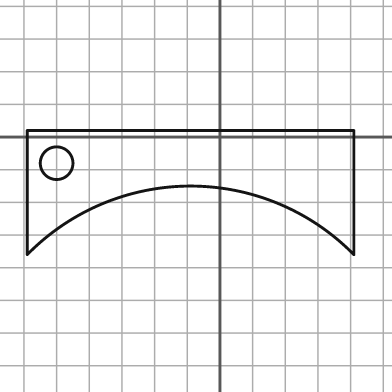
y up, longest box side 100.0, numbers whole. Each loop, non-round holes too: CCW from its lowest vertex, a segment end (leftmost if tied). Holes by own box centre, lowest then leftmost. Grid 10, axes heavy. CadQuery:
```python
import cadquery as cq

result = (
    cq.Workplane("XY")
    .moveTo(-59.0, -36.0)
    .threePointArc((-9.0, -15.0), (41.0, -36.0))
    .lineTo(41.0, 2.0)
    .lineTo(-59.0, 2.0)
    .close()
    .moveTo(-50.0, -8.0)
    .circle(5.0)
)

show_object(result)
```